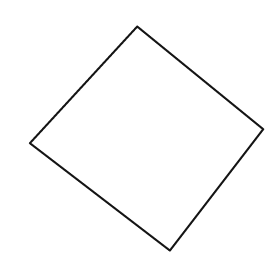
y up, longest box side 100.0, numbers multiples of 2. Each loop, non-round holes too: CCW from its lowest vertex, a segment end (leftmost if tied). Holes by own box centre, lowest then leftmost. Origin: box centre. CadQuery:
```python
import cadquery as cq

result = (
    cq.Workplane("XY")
    .moveTo(10.0, -48.0)
    .lineTo(50.0, 4.0)
    .lineTo(-4.0, 48.0)
    .lineTo(-50.0, -2.0)
    .close()
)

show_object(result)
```